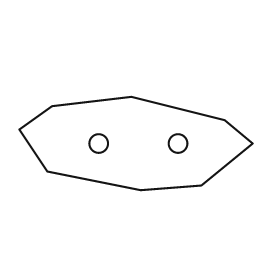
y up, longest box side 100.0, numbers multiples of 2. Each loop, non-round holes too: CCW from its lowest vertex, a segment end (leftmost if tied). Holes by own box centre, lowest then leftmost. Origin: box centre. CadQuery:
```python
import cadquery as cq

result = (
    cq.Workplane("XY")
    .moveTo(2.0, -20.0)
    .lineTo(28.0, -18.0)
    .lineTo(50.0, 0.0)
    .lineTo(38.0, 10.0)
    .lineTo(-2.0, 20.0)
    .lineTo(-36.0, 16.0)
    .lineTo(-50.0, 6.0)
    .lineTo(-38.0, -12.0)
    .close()
    .moveTo(-16.0, 0.0)
    .circle(4.0)
    .moveTo(18.0, 0.0)
    .circle(4.0)
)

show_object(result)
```